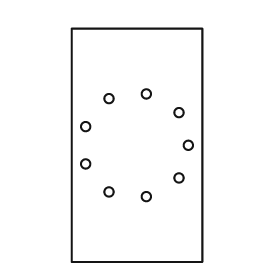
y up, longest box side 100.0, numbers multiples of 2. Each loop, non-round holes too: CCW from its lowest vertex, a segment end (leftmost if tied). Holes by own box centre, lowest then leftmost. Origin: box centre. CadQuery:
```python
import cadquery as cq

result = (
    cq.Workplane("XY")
    .moveTo(-28.0, -50.0)
    .lineTo(28.0, -50.0)
    .lineTo(28.0, 50.0)
    .lineTo(-28.0, 50.0)
    .close()
    .moveTo(4.0, -22.0)
    .circle(2.0)
    .moveTo(-12.0, -20.0)
    .circle(2.0)
    .moveTo(18.0, -14.0)
    .circle(2.0)
    .moveTo(-22.0, -8.0)
    .circle(2.0)
    .moveTo(22.0, 0.0)
    .circle(2.0)
    .moveTo(-22.0, 8.0)
    .circle(2.0)
    .moveTo(18.0, 14.0)
    .circle(2.0)
    .moveTo(-12.0, 20.0)
    .circle(2.0)
    .moveTo(4.0, 22.0)
    .circle(2.0)
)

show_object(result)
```